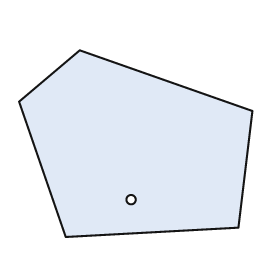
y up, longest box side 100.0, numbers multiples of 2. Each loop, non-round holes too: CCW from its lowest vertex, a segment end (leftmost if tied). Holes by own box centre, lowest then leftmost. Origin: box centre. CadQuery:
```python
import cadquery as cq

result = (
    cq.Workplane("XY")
    .moveTo(-30.0, -40.0)
    .lineTo(44.0, -36.0)
    .lineTo(50.0, 14.0)
    .lineTo(-24.0, 40.0)
    .lineTo(-50.0, 18.0)
    .close()
    .moveTo(-2.0, -24.0)
    .circle(2.0)
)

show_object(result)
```